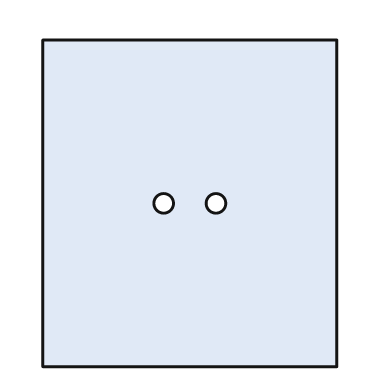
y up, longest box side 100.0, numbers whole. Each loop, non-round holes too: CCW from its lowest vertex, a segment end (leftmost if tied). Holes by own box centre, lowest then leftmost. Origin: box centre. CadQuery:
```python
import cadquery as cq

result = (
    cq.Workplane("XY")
    .moveTo(-45.0, -50.0)
    .lineTo(45.0, -50.0)
    .lineTo(45.0, 50.0)
    .lineTo(-45.0, 50.0)
    .close()
    .moveTo(-8.0, 0.0)
    .circle(3.0)
    .moveTo(8.0, 0.0)
    .circle(3.0)
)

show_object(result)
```